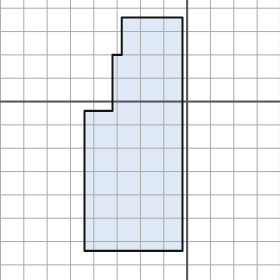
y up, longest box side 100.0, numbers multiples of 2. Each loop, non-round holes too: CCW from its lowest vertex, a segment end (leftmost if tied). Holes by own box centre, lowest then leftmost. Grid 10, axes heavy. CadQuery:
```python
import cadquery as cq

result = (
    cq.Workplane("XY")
    .moveTo(-44.0, -64.0)
    .lineTo(-2.0, -64.0)
    .lineTo(-2.0, 36.0)
    .lineTo(-28.0, 36.0)
    .lineTo(-28.0, 20.0)
    .lineTo(-32.0, 20.0)
    .lineTo(-32.0, -4.0)
    .lineTo(-44.0, -4.0)
    .close()
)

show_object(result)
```